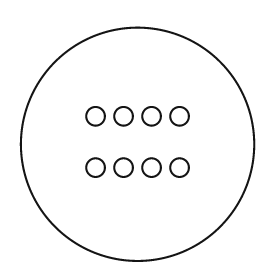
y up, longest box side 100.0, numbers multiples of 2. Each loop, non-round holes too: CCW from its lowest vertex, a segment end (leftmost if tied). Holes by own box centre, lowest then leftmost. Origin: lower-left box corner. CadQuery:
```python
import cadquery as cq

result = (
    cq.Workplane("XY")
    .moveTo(50.0, 50.0)
    .circle(50.0)
    .moveTo(32.0, 40.0)
    .circle(4.0)
    .moveTo(44.0, 40.0)
    .circle(4.0)
    .moveTo(56.0, 40.0)
    .circle(4.0)
    .moveTo(68.0, 40.0)
    .circle(4.0)
    .moveTo(32.0, 62.0)
    .circle(4.0)
    .moveTo(44.0, 62.0)
    .circle(4.0)
    .moveTo(56.0, 62.0)
    .circle(4.0)
    .moveTo(68.0, 62.0)
    .circle(4.0)
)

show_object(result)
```